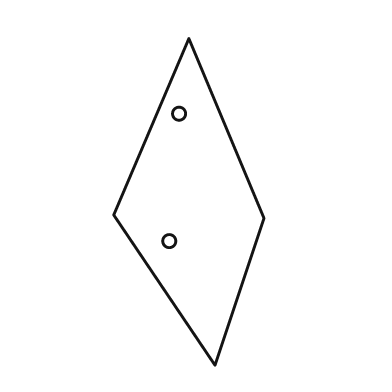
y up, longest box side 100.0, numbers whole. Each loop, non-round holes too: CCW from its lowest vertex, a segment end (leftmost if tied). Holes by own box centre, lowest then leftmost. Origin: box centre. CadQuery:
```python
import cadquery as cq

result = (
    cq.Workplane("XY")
    .moveTo(8.0, -50.0)
    .lineTo(23.0, -5.0)
    .lineTo(0.0, 50.0)
    .lineTo(-23.0, -4.0)
    .close()
    .moveTo(-6.0, -12.0)
    .circle(2.0)
    .moveTo(-3.0, 27.0)
    .circle(2.0)
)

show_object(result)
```